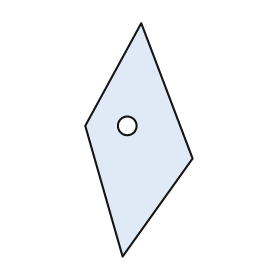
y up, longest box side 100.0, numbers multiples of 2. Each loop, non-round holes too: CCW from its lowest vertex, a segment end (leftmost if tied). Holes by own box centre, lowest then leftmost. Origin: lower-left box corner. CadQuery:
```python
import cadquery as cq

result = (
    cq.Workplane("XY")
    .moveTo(16.0, 0.0)
    .lineTo(46.0, 42.0)
    .lineTo(24.0, 100.0)
    .lineTo(0.0, 56.0)
    .close()
    .moveTo(18.0, 56.0)
    .circle(4.0)
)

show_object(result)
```